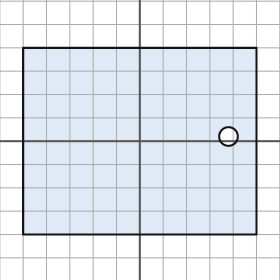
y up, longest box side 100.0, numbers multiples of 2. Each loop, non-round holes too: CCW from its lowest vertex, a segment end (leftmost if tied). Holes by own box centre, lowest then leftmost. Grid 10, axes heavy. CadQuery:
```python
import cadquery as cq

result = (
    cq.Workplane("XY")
    .moveTo(-50.0, -40.0)
    .lineTo(50.0, -40.0)
    .lineTo(50.0, 40.0)
    .lineTo(-50.0, 40.0)
    .close()
    .moveTo(38.0, 2.0)
    .circle(4.0)
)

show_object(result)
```